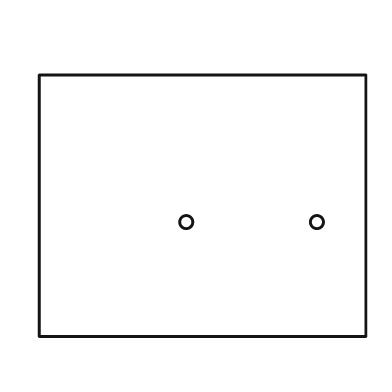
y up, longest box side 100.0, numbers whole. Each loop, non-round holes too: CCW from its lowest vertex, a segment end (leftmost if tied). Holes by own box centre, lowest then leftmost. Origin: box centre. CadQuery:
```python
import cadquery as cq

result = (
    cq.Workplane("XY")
    .moveTo(-50.0, -40.0)
    .lineTo(50.0, -40.0)
    .lineTo(50.0, 40.0)
    .lineTo(-50.0, 40.0)
    .close()
    .moveTo(-5.0, -5.0)
    .circle(2.0)
    .moveTo(35.0, -5.0)
    .circle(2.0)
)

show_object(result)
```